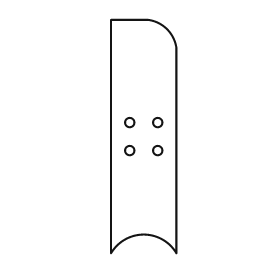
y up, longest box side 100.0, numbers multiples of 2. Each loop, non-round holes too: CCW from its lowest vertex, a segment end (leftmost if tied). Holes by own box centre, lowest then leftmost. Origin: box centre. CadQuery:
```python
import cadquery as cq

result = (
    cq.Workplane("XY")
    .moveTo(-14.0, -50.0)
    .threePointArc((0.0, -42.0), (14.0, -50.0))
    .lineTo(14.0, 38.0)
    .threePointArc((10.0, 46.0), (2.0, 50.0))
    .lineTo(-14.0, 50.0)
    .close()
    .moveTo(-6.0, -6.0)
    .circle(2.0)
    .moveTo(6.0, -6.0)
    .circle(2.0)
    .moveTo(-6.0, 6.0)
    .circle(2.0)
    .moveTo(6.0, 6.0)
    .circle(2.0)
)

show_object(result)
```